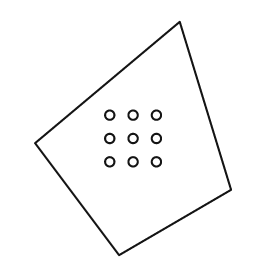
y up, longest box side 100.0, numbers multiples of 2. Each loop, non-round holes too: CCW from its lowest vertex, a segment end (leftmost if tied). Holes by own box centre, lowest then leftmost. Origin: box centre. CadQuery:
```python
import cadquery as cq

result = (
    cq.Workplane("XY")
    .moveTo(-6.0, -50.0)
    .lineTo(42.0, -22.0)
    .lineTo(20.0, 50.0)
    .lineTo(-42.0, -2.0)
    .close()
    .moveTo(-10.0, -10.0)
    .circle(2.0)
    .moveTo(0.0, -10.0)
    .circle(2.0)
    .moveTo(10.0, -10.0)
    .circle(2.0)
    .moveTo(-10.0, 0.0)
    .circle(2.0)
    .moveTo(0.0, 0.0)
    .circle(2.0)
    .moveTo(10.0, 0.0)
    .circle(2.0)
    .moveTo(-10.0, 10.0)
    .circle(2.0)
    .moveTo(0.0, 10.0)
    .circle(2.0)
    .moveTo(10.0, 10.0)
    .circle(2.0)
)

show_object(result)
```